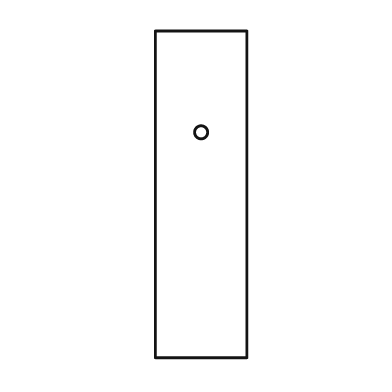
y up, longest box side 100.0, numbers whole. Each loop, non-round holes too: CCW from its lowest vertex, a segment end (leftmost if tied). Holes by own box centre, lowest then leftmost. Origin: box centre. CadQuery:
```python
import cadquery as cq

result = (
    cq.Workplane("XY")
    .moveTo(-14.0, -50.0)
    .lineTo(14.0, -50.0)
    .lineTo(14.0, 50.0)
    .lineTo(-14.0, 50.0)
    .close()
    .moveTo(0.0, 19.0)
    .circle(2.0)
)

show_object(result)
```